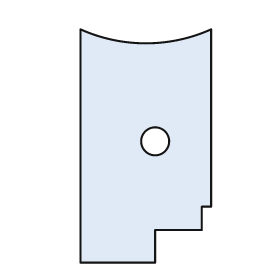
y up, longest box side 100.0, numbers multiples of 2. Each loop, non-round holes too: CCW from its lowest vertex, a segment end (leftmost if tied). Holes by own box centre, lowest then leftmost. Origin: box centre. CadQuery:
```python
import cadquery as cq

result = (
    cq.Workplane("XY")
    .moveTo(-28.0, -50.0)
    .lineTo(4.0, -50.0)
    .lineTo(4.0, -36.0)
    .lineTo(24.0, -36.0)
    .lineTo(24.0, -26.0)
    .lineTo(28.0, -26.0)
    .lineTo(28.0, 50.0)
    .threePointArc((0.0, 44.0), (-28.0, 50.0))
    .close()
    .moveTo(4.0, 2.0)
    .circle(6.0)
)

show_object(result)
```